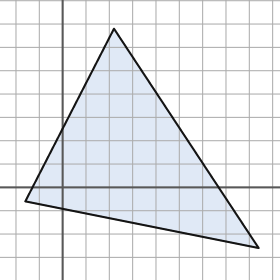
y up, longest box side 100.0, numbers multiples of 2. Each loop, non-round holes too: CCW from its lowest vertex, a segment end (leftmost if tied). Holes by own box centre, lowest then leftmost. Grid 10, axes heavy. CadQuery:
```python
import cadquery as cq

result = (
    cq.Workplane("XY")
    .moveTo(84.0, -26.0)
    .lineTo(22.0, 68.0)
    .lineTo(-16.0, -6.0)
    .close()
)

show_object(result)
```